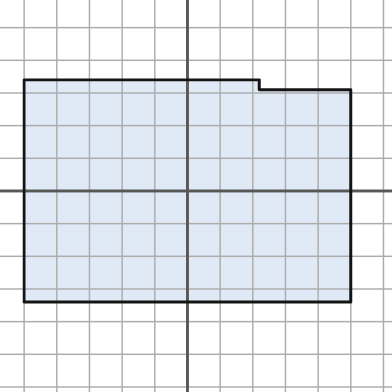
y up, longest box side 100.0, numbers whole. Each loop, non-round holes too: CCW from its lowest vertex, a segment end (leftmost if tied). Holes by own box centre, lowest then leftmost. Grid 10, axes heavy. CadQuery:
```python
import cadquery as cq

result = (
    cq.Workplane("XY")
    .moveTo(-50.0, -34.0)
    .lineTo(50.0, -34.0)
    .lineTo(50.0, 31.0)
    .lineTo(22.0, 31.0)
    .lineTo(22.0, 34.0)
    .lineTo(-50.0, 34.0)
    .close()
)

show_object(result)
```